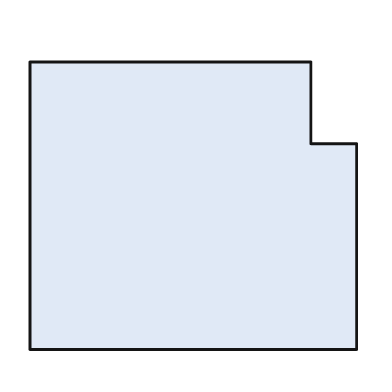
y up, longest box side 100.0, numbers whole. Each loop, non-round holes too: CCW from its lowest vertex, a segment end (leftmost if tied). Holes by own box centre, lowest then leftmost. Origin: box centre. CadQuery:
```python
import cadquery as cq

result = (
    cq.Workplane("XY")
    .moveTo(-50.0, -44.0)
    .lineTo(50.0, -44.0)
    .lineTo(50.0, 19.0)
    .lineTo(36.0, 19.0)
    .lineTo(36.0, 44.0)
    .lineTo(-50.0, 44.0)
    .close()
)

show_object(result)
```